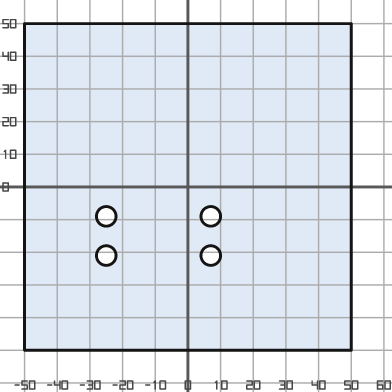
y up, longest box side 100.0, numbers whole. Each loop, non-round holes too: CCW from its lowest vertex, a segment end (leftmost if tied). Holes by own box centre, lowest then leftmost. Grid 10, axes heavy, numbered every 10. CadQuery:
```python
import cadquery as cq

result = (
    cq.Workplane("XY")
    .moveTo(-50.0, -50.0)
    .lineTo(50.0, -50.0)
    .lineTo(50.0, 50.0)
    .lineTo(-50.0, 50.0)
    .close()
    .moveTo(-25.0, -21.0)
    .circle(3.0)
    .moveTo(7.0, -21.0)
    .circle(3.0)
    .moveTo(-25.0, -9.0)
    .circle(3.0)
    .moveTo(7.0, -9.0)
    .circle(3.0)
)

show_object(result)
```